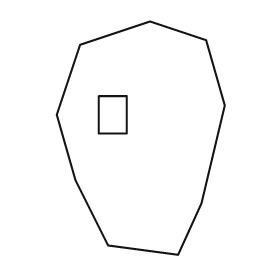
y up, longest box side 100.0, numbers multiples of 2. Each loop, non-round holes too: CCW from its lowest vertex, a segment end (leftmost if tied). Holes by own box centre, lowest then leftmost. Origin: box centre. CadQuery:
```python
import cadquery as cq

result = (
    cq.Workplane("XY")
    .moveTo(16.0, -50.0)
    .lineTo(26.0, -28.0)
    .lineTo(36.0, 14.0)
    .lineTo(28.0, 42.0)
    .lineTo(4.0, 50.0)
    .lineTo(-26.0, 40.0)
    .lineTo(-36.0, 10.0)
    .lineTo(-28.0, -18.0)
    .lineTo(-14.0, -46.0)
    .close()
    .moveTo(-18.0, 2.0)
    .lineTo(-6.0, 2.0)
    .lineTo(-6.0, 18.0)
    .lineTo(-18.0, 18.0)
    .close()
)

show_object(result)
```